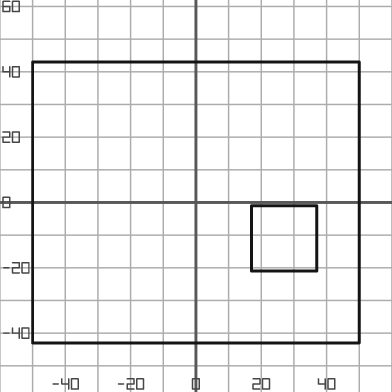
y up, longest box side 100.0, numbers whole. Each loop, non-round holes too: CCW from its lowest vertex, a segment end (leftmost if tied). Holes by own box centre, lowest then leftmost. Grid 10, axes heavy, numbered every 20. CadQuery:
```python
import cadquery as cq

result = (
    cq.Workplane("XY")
    .moveTo(-50.0, -43.0)
    .lineTo(50.0, -43.0)
    .lineTo(50.0, 43.0)
    .lineTo(-50.0, 43.0)
    .close()
    .moveTo(17.0, -21.0)
    .lineTo(37.0, -21.0)
    .lineTo(37.0, -1.0)
    .lineTo(17.0, -1.0)
    .close()
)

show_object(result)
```